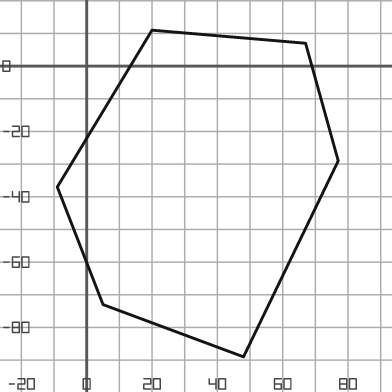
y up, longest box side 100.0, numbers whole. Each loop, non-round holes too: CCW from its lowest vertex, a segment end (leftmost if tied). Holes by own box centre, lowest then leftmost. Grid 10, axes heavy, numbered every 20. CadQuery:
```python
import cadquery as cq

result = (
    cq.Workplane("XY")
    .moveTo(48.0, -89.0)
    .lineTo(77.0, -29.0)
    .lineTo(67.0, 7.0)
    .lineTo(20.0, 11.0)
    .lineTo(-9.0, -37.0)
    .lineTo(5.0, -73.0)
    .close()
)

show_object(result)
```